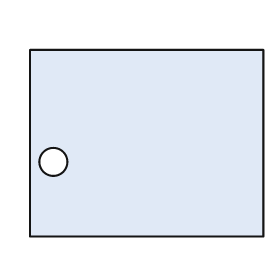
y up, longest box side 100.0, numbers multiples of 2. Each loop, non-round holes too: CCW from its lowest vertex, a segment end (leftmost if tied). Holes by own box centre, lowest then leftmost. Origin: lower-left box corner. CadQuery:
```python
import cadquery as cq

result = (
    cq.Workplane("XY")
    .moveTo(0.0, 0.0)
    .lineTo(100.0, 0.0)
    .lineTo(100.0, 80.0)
    .lineTo(0.0, 80.0)
    .close()
    .moveTo(10.0, 32.0)
    .circle(6.0)
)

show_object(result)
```